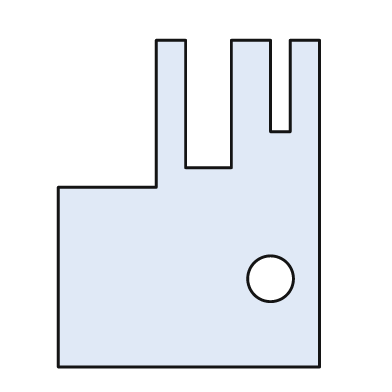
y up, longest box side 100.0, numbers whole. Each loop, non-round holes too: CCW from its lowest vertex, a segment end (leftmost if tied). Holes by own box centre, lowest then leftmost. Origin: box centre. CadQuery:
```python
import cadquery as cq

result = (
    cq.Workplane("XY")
    .moveTo(-40.0, -50.0)
    .lineTo(40.0, -50.0)
    .lineTo(40.0, 50.0)
    .lineTo(31.0, 50.0)
    .lineTo(31.0, 22.0)
    .lineTo(25.0, 22.0)
    .lineTo(25.0, 50.0)
    .lineTo(13.0, 50.0)
    .lineTo(13.0, 11.0)
    .lineTo(-1.0, 11.0)
    .lineTo(-1.0, 50.0)
    .lineTo(-10.0, 50.0)
    .lineTo(-10.0, 5.0)
    .lineTo(-40.0, 5.0)
    .close()
    .moveTo(25.0, -23.0)
    .circle(7.0)
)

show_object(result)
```